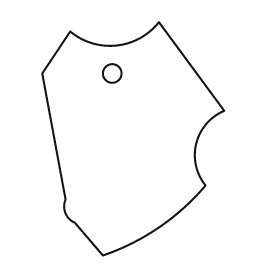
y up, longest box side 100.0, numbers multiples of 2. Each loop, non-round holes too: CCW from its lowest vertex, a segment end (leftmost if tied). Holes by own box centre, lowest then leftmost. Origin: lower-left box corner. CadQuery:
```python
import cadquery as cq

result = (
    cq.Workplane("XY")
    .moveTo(26.0, 0.0)
    .threePointArc((50.0, 12.0), (70.0, 30.0))
    .threePointArc((66.0, 48.0), (78.0, 62.0))
    .lineTo(50.0, 100.0)
    .threePointArc((32.0, 90.0), (12.0, 96.0))
    .lineTo(0.0, 78.0)
    .lineTo(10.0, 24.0)
    .threePointArc((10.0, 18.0), (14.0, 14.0))
    .close()
    .moveTo(30.0, 78.0)
    .circle(4.0)
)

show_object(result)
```